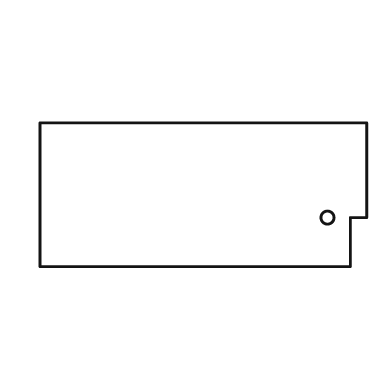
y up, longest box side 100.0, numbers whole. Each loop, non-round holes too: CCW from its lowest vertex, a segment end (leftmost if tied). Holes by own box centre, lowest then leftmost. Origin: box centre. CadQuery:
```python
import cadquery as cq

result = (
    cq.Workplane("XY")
    .moveTo(-50.0, -22.0)
    .lineTo(45.0, -22.0)
    .lineTo(45.0, -7.0)
    .lineTo(50.0, -7.0)
    .lineTo(50.0, 22.0)
    .lineTo(-50.0, 22.0)
    .close()
    .moveTo(38.0, -7.0)
    .circle(2.0)
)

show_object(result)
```